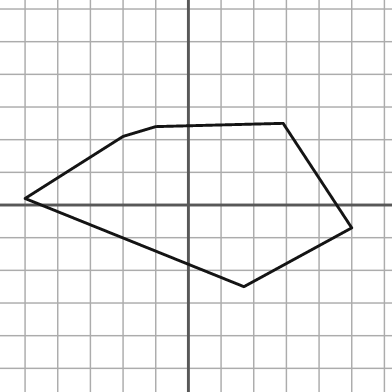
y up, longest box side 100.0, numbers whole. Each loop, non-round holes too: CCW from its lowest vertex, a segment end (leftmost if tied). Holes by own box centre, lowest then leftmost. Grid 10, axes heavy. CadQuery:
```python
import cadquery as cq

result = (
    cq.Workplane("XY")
    .moveTo(17.0, -25.0)
    .lineTo(50.0, -7.0)
    .lineTo(29.0, 25.0)
    .lineTo(-10.0, 24.0)
    .lineTo(-20.0, 21.0)
    .lineTo(-50.0, 2.0)
    .close()
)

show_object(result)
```